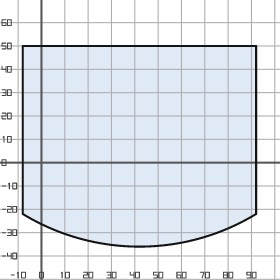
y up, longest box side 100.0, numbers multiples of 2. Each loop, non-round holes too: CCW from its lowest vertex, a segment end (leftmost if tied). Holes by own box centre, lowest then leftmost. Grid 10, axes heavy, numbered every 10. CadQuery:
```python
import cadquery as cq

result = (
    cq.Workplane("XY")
    .moveTo(-8.0, -22.0)
    .threePointArc((42.0, -36.0), (92.0, -22.0))
    .lineTo(92.0, 50.0)
    .lineTo(-8.0, 50.0)
    .close()
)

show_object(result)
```